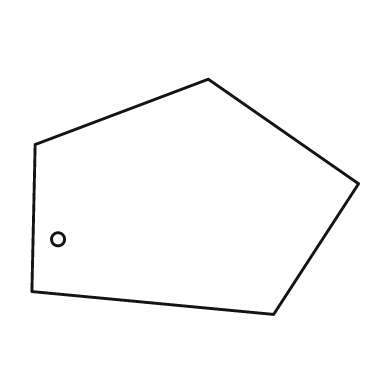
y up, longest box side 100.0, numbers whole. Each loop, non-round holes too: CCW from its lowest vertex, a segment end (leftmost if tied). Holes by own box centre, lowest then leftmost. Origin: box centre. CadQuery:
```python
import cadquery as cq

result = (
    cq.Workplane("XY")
    .moveTo(24.0, -36.0)
    .lineTo(50.0, 4.0)
    .lineTo(4.0, 36.0)
    .lineTo(-49.0, 16.0)
    .lineTo(-50.0, -29.0)
    .close()
    .moveTo(-42.0, -13.0)
    .circle(2.0)
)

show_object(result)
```